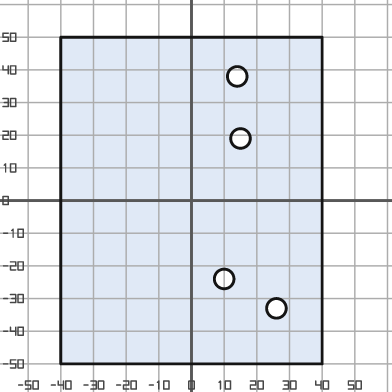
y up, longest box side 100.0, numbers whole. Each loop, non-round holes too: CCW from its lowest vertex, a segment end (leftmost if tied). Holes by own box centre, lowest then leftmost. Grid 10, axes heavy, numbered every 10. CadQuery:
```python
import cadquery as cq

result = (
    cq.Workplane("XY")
    .moveTo(-40.0, -50.0)
    .lineTo(40.0, -50.0)
    .lineTo(40.0, 50.0)
    .lineTo(-40.0, 50.0)
    .close()
    .moveTo(26.0, -33.0)
    .circle(3.0)
    .moveTo(10.0, -24.0)
    .circle(3.0)
    .moveTo(15.0, 19.0)
    .circle(3.0)
    .moveTo(14.0, 38.0)
    .circle(3.0)
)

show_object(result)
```